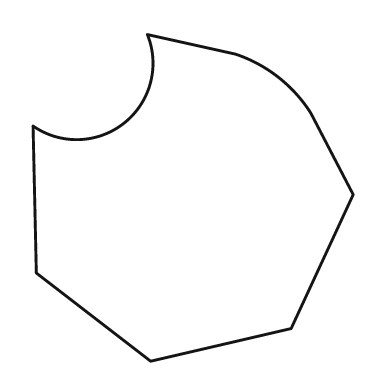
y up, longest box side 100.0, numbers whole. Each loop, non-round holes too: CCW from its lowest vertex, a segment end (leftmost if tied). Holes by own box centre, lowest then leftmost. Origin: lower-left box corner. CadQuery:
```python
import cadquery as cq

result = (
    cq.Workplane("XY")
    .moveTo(36.0, 0.0)
    .lineTo(79.0, 10.0)
    .lineTo(98.0, 51.0)
    .lineTo(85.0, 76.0)
    .threePointArc((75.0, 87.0), (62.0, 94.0))
    .lineTo(35.0, 100.0)
    .threePointArc((28.0, 73.0), (0.0, 72.0))
    .lineTo(1.0, 27.0)
    .close()
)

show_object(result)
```